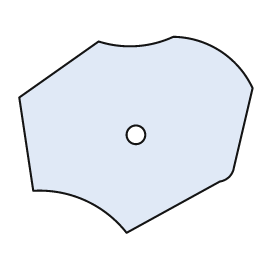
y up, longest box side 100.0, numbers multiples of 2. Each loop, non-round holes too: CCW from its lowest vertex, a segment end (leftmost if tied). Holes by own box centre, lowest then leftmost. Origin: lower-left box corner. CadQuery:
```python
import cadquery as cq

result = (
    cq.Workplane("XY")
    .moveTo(46.0, 0.0)
    .lineTo(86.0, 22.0)
    .threePointArc((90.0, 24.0), (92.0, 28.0))
    .lineTo(100.0, 62.0)
    .threePointArc((86.0, 78.0), (66.0, 84.0))
    .threePointArc((50.0, 80.0), (34.0, 82.0))
    .lineTo(0.0, 58.0)
    .lineTo(6.0, 18.0)
    .threePointArc((28.0, 14.0), (46.0, 0.0))
    .close()
    .moveTo(50.0, 42.0)
    .circle(4.0)
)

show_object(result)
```